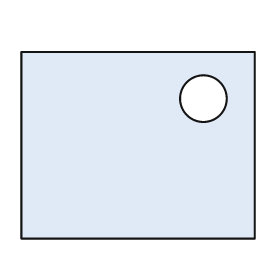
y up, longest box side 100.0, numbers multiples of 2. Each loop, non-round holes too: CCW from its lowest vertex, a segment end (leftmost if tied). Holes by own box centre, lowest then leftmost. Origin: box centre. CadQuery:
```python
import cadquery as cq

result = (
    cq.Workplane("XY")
    .moveTo(-50.0, -40.0)
    .lineTo(50.0, -40.0)
    .lineTo(50.0, 40.0)
    .lineTo(-50.0, 40.0)
    .close()
    .moveTo(28.0, 20.0)
    .circle(10.0)
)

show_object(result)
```